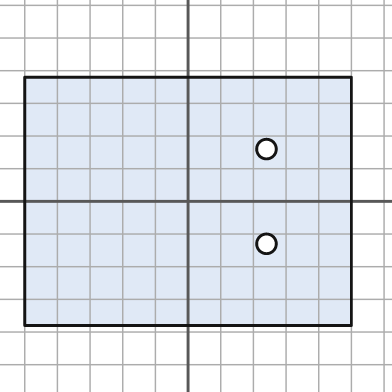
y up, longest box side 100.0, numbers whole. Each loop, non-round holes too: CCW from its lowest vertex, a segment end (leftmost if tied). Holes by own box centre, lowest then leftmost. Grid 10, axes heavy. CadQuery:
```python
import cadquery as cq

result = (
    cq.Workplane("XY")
    .moveTo(-50.0, -38.0)
    .lineTo(50.0, -38.0)
    .lineTo(50.0, 38.0)
    .lineTo(-50.0, 38.0)
    .close()
    .moveTo(24.0, -13.0)
    .circle(3.0)
    .moveTo(24.0, 16.0)
    .circle(3.0)
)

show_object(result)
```